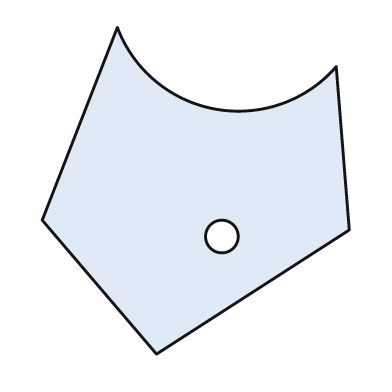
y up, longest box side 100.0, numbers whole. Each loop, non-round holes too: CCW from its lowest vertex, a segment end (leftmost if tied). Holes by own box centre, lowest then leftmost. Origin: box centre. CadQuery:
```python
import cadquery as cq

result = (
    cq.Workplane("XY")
    .moveTo(-12.0, -50.0)
    .lineTo(47.0, -12.0)
    .lineTo(43.0, 38.0)
    .threePointArc((6.0, 25.0), (-24.0, 50.0))
    .lineTo(-47.0, -9.0)
    .close()
    .moveTo(8.0, -14.0)
    .circle(5.0)
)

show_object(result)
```